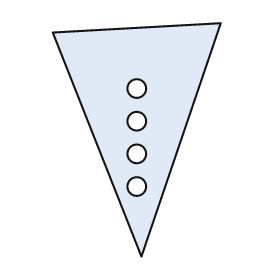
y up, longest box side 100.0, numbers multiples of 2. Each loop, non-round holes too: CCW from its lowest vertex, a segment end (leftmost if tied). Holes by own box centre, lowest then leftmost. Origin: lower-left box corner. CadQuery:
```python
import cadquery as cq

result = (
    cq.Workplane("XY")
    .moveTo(38.0, 0.0)
    .lineTo(72.0, 100.0)
    .lineTo(0.0, 96.0)
    .close()
    .moveTo(36.0, 30.0)
    .circle(4.0)
    .moveTo(36.0, 44.0)
    .circle(4.0)
    .moveTo(36.0, 58.0)
    .circle(4.0)
    .moveTo(36.0, 72.0)
    .circle(4.0)
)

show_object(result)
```